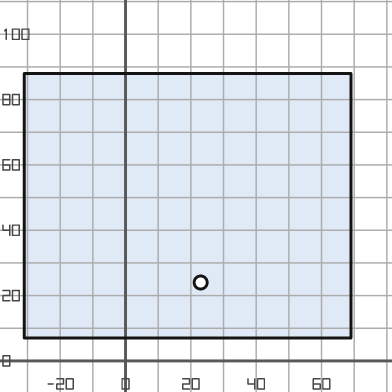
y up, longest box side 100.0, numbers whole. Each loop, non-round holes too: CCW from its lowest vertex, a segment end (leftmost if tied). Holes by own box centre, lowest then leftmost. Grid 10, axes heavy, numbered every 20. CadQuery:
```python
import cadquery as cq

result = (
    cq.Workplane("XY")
    .moveTo(-31.0, 7.0)
    .lineTo(69.0, 7.0)
    .lineTo(69.0, 88.0)
    .lineTo(-31.0, 88.0)
    .close()
    .moveTo(23.0, 24.0)
    .circle(2.0)
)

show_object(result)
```